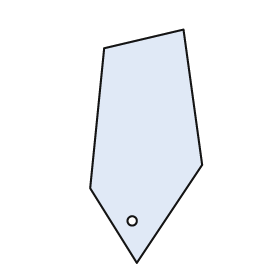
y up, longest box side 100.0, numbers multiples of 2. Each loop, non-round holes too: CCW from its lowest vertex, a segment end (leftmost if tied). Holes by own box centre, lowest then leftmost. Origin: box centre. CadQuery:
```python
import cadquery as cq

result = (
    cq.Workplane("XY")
    .moveTo(-4.0, -50.0)
    .lineTo(24.0, -8.0)
    .lineTo(16.0, 50.0)
    .lineTo(-18.0, 42.0)
    .lineTo(-24.0, -18.0)
    .close()
    .moveTo(-6.0, -32.0)
    .circle(2.0)
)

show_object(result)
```